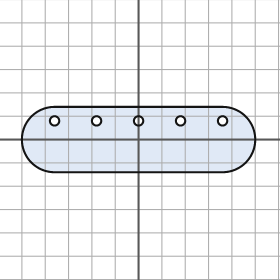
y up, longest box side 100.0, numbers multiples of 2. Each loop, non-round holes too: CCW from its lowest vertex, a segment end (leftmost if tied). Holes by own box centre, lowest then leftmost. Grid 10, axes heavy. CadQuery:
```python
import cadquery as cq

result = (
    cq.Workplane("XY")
    .moveTo(-36.0, -14.0)
    .lineTo(36.0, -14.0)
    .threePointArc((50.0, 0.0), (36.0, 14.0))
    .lineTo(-36.0, 14.0)
    .threePointArc((-50.0, 0.0), (-36.0, -14.0))
    .close()
    .moveTo(-36.0, 8.0)
    .circle(2.0)
    .moveTo(-18.0, 8.0)
    .circle(2.0)
    .moveTo(0.0, 8.0)
    .circle(2.0)
    .moveTo(18.0, 8.0)
    .circle(2.0)
    .moveTo(36.0, 8.0)
    .circle(2.0)
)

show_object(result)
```